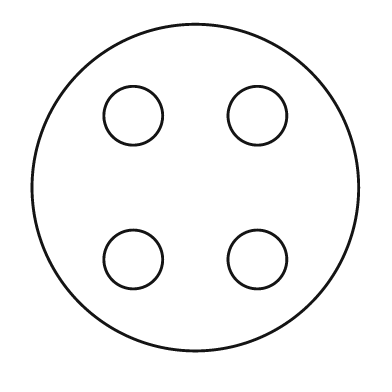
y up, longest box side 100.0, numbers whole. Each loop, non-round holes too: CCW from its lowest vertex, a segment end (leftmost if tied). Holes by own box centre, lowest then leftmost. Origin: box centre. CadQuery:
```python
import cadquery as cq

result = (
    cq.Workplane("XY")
    .moveTo(0.0, 0.0)
    .circle(50.0)
    .moveTo(-19.0, -22.0)
    .circle(9.0)
    .moveTo(19.0, -22.0)
    .circle(9.0)
    .moveTo(-19.0, 22.0)
    .circle(9.0)
    .moveTo(19.0, 22.0)
    .circle(9.0)
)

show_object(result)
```